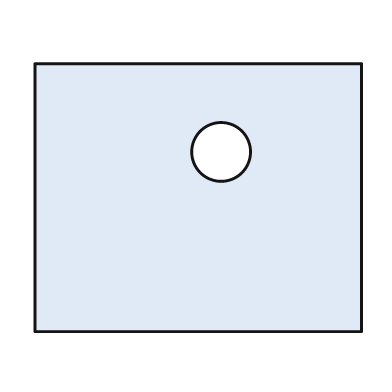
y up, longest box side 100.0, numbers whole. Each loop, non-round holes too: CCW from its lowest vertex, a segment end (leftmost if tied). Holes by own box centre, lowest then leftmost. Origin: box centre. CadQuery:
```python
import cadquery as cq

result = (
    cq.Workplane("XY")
    .moveTo(-50.0, -41.0)
    .lineTo(50.0, -41.0)
    .lineTo(50.0, 41.0)
    .lineTo(-50.0, 41.0)
    .close()
    .moveTo(7.0, 14.0)
    .circle(9.0)
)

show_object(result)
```